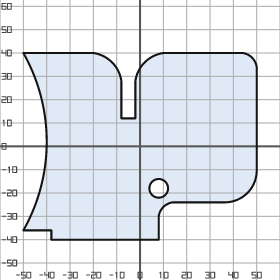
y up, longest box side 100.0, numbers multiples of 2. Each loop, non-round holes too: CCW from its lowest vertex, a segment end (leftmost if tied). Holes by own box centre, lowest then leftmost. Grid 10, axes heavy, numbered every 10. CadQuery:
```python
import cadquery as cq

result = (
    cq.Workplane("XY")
    .moveTo(-38.0, -40.0)
    .lineTo(8.0, -40.0)
    .lineTo(8.0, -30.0)
    .threePointArc((10.0, -26.0), (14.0, -24.0))
    .lineTo(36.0, -24.0)
    .threePointArc((46.0, -20.0), (50.0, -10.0))
    .lineTo(50.0, 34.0)
    .threePointArc((48.0, 38.0), (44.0, 40.0))
    .lineTo(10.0, 40.0)
    .threePointArc((2.0, 36.0), (-2.0, 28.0))
    .lineTo(-2.0, 12.0)
    .lineTo(-8.0, 12.0)
    .lineTo(-8.0, 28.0)
    .threePointArc((-12.0, 36.0), (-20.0, 40.0))
    .lineTo(-50.0, 40.0)
    .threePointArc((-40.0, 2.0), (-50.0, -36.0))
    .lineTo(-38.0, -36.0)
    .close()
    .moveTo(8.0, -18.0)
    .circle(4.0)
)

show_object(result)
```